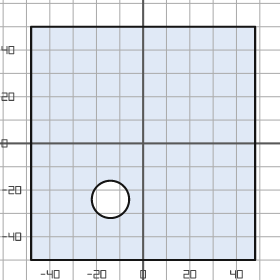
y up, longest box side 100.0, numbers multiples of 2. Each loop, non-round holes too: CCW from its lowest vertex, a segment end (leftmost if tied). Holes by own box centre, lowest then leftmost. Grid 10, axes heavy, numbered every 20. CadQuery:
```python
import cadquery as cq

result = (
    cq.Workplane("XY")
    .moveTo(-48.0, -50.0)
    .lineTo(48.0, -50.0)
    .lineTo(48.0, 50.0)
    .lineTo(-48.0, 50.0)
    .close()
    .moveTo(-14.0, -24.0)
    .circle(8.0)
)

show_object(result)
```